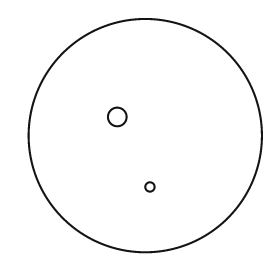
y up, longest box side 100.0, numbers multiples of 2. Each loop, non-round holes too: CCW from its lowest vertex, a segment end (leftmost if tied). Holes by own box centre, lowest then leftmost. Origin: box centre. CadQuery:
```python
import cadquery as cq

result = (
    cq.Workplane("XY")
    .moveTo(0.0, 0.0)
    .circle(50.0)
    .moveTo(2.0, -22.0)
    .circle(2.0)
    .moveTo(-12.0, 8.0)
    .circle(4.0)
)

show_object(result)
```